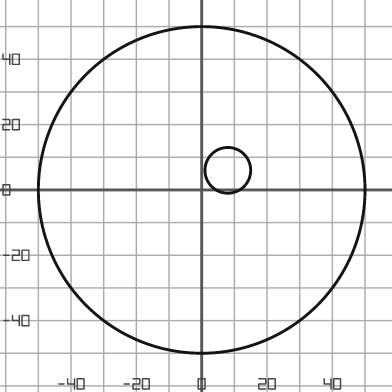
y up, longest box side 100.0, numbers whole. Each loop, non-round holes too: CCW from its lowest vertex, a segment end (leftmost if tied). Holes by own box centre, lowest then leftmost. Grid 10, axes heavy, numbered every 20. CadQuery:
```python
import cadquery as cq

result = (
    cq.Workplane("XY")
    .moveTo(0.0, 0.0)
    .circle(50.0)
    .moveTo(8.0, 6.0)
    .circle(7.0)
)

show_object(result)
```